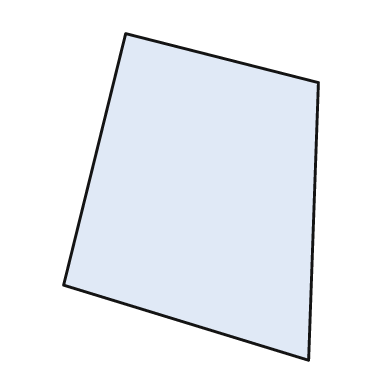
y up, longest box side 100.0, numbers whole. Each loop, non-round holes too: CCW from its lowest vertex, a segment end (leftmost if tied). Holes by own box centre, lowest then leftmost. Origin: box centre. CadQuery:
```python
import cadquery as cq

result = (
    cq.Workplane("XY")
    .moveTo(36.0, -50.0)
    .lineTo(39.0, 35.0)
    .lineTo(-20.0, 50.0)
    .lineTo(-39.0, -27.0)
    .close()
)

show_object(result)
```